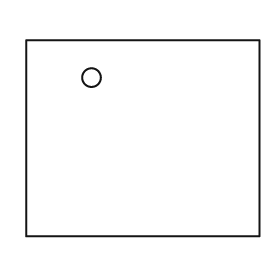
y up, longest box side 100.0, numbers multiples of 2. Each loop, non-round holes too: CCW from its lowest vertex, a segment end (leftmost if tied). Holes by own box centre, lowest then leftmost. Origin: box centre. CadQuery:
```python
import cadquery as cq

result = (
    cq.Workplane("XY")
    .moveTo(-50.0, -42.0)
    .lineTo(50.0, -42.0)
    .lineTo(50.0, 42.0)
    .lineTo(-50.0, 42.0)
    .close()
    .moveTo(-22.0, 26.0)
    .circle(4.0)
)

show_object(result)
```